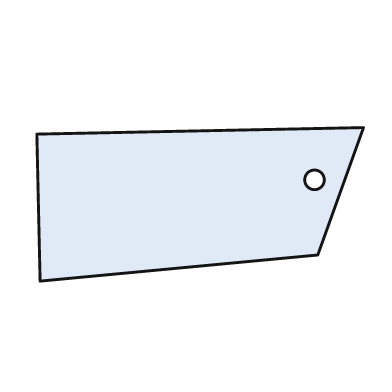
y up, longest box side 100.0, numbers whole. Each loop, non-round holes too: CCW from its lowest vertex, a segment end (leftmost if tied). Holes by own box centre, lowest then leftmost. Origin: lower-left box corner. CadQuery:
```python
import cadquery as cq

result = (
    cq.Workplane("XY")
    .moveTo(1.0, 0.0)
    .lineTo(86.0, 8.0)
    .lineTo(100.0, 47.0)
    .lineTo(0.0, 45.0)
    .close()
    .moveTo(85.0, 31.0)
    .circle(3.0)
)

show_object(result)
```